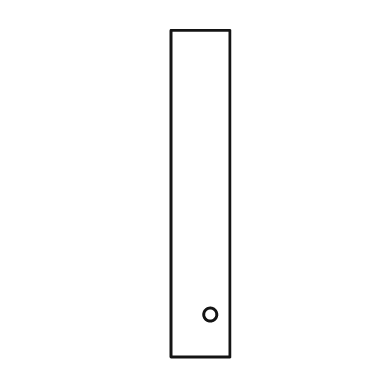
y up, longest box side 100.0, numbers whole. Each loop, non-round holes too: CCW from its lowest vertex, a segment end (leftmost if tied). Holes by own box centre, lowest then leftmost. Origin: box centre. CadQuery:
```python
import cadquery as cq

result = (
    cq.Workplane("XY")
    .moveTo(-9.0, -50.0)
    .lineTo(9.0, -50.0)
    .lineTo(9.0, 50.0)
    .lineTo(-9.0, 50.0)
    .close()
    .moveTo(3.0, -37.0)
    .circle(2.0)
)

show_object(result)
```